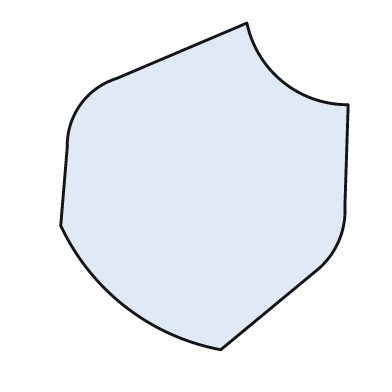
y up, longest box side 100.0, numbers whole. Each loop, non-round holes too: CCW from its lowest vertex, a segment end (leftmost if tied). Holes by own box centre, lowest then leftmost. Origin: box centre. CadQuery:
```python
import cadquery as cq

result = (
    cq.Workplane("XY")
    .moveTo(5.0, -50.0)
    .lineTo(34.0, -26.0)
    .threePointArc((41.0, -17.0), (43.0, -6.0))
    .lineTo(44.0, 25.0)
    .threePointArc((24.0, 32.0), (13.0, 50.0))
    .lineTo(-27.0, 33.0)
    .threePointArc((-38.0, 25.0), (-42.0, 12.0))
    .lineTo(-44.0, -12.0)
    .threePointArc((-24.0, -37.0), (5.0, -50.0))
    .close()
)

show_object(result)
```